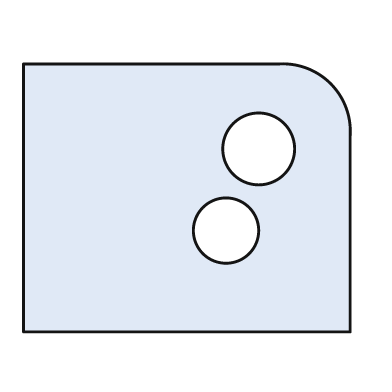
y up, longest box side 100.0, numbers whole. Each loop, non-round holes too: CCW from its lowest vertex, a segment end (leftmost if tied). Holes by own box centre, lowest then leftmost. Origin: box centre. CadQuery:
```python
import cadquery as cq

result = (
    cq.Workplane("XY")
    .moveTo(-50.0, -41.0)
    .lineTo(50.0, -41.0)
    .lineTo(50.0, 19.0)
    .threePointArc((44.0, 35.0), (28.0, 41.0))
    .lineTo(-50.0, 41.0)
    .close()
    .moveTo(12.0, -10.0)
    .circle(10.0)
    .moveTo(22.0, 15.0)
    .circle(11.0)
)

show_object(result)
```